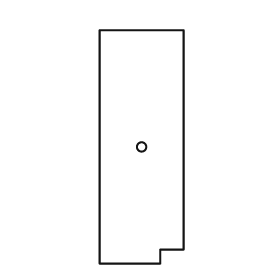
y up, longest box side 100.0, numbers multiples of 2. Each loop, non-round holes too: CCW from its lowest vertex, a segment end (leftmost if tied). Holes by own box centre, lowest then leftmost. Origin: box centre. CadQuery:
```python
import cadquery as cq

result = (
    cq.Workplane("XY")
    .moveTo(-18.0, -50.0)
    .lineTo(8.0, -50.0)
    .lineTo(8.0, -44.0)
    .lineTo(18.0, -44.0)
    .lineTo(18.0, 50.0)
    .lineTo(-18.0, 50.0)
    .close()
    .moveTo(0.0, 0.0)
    .circle(2.0)
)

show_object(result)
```